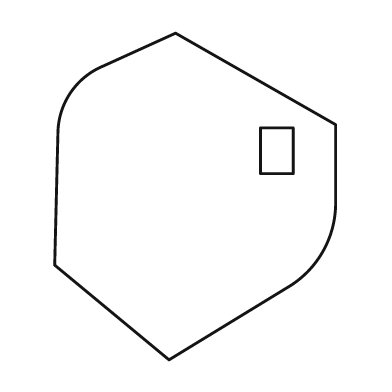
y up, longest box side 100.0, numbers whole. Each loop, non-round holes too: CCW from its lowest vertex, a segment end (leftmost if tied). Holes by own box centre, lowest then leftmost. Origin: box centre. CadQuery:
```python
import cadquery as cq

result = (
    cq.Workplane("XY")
    .moveTo(-8.0, -50.0)
    .lineTo(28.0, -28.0)
    .threePointArc((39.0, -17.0), (43.0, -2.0))
    .lineTo(43.0, 22.0)
    .lineTo(-6.0, 50.0)
    .lineTo(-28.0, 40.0)
    .threePointArc((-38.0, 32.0), (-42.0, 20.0))
    .lineTo(-43.0, -21.0)
    .close()
    .moveTo(20.0, 7.0)
    .lineTo(30.0, 7.0)
    .lineTo(30.0, 21.0)
    .lineTo(20.0, 21.0)
    .close()
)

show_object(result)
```